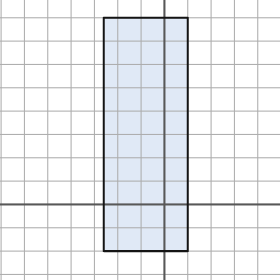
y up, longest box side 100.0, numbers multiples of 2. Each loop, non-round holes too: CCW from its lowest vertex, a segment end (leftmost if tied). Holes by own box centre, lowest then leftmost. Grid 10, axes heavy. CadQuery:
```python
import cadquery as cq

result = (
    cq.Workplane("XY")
    .moveTo(-26.0, -20.0)
    .lineTo(10.0, -20.0)
    .lineTo(10.0, 80.0)
    .lineTo(-26.0, 80.0)
    .close()
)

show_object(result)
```